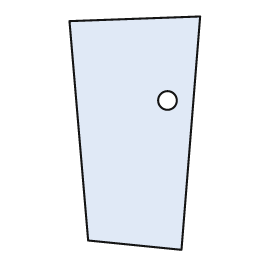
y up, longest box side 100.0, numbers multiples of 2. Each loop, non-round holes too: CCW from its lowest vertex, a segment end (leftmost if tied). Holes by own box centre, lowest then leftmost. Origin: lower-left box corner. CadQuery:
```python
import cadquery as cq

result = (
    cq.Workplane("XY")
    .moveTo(48.0, 0.0)
    .lineTo(56.0, 100.0)
    .lineTo(0.0, 98.0)
    .lineTo(8.0, 4.0)
    .close()
    .moveTo(42.0, 64.0)
    .circle(4.0)
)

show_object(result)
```